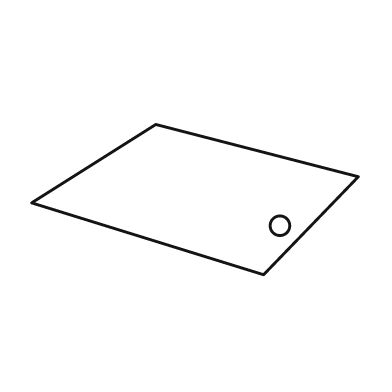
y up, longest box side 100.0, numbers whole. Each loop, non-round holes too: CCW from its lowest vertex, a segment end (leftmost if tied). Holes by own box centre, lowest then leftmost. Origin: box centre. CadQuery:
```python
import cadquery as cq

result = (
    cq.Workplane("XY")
    .moveTo(21.0, -23.0)
    .lineTo(50.0, 7.0)
    .lineTo(-12.0, 23.0)
    .lineTo(-50.0, -1.0)
    .close()
    .moveTo(26.0, -8.0)
    .circle(3.0)
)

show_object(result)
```